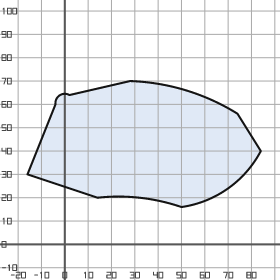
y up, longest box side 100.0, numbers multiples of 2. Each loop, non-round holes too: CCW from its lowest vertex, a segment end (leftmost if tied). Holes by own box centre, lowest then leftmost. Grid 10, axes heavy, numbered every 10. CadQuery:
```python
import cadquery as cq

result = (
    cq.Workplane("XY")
    .moveTo(50.0, 16.0)
    .threePointArc((70.0, 24.0), (84.0, 40.0))
    .lineTo(74.0, 56.0)
    .threePointArc((52.0, 66.0), (28.0, 70.0))
    .lineTo(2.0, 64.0)
    .threePointArc((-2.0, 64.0), (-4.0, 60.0))
    .lineTo(-16.0, 30.0)
    .lineTo(14.0, 20.0)
    .threePointArc((32.0, 20.0), (50.0, 16.0))
    .close()
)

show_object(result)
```